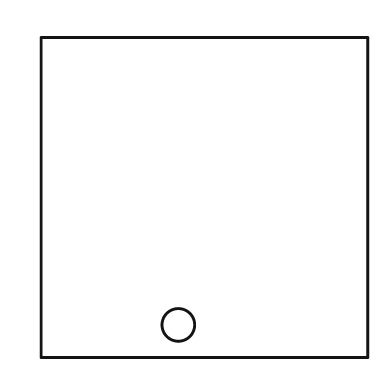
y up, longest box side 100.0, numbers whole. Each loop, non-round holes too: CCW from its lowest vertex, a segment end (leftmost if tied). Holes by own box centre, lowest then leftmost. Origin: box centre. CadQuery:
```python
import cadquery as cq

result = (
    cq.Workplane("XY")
    .moveTo(-50.0, -49.0)
    .lineTo(50.0, -49.0)
    .lineTo(50.0, 49.0)
    .lineTo(-50.0, 49.0)
    .close()
    .moveTo(-8.0, -39.0)
    .circle(5.0)
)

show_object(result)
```